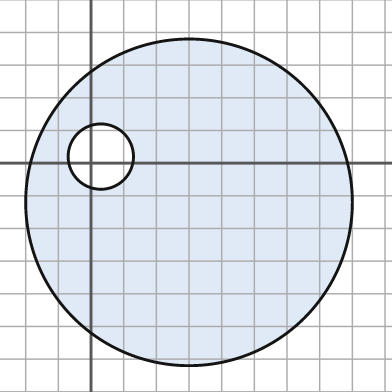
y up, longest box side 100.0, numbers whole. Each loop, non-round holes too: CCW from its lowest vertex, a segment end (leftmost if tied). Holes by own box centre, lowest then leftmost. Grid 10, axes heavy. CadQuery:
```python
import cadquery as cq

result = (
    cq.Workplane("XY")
    .moveTo(30.0, -12.0)
    .circle(50.0)
    .moveTo(3.0, 2.0)
    .circle(10.0)
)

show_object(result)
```